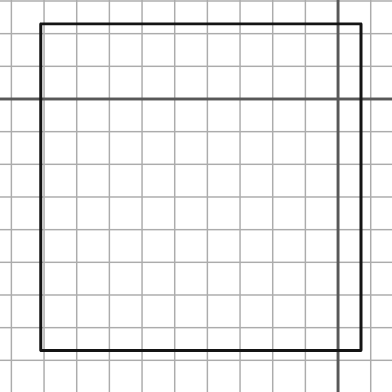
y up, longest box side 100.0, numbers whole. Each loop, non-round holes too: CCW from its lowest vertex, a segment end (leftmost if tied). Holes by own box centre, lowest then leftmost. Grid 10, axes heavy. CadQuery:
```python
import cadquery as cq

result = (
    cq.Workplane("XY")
    .moveTo(-91.0, -77.0)
    .lineTo(7.0, -77.0)
    .lineTo(7.0, 23.0)
    .lineTo(-91.0, 23.0)
    .close()
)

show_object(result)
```